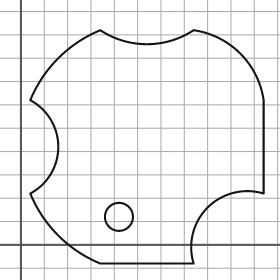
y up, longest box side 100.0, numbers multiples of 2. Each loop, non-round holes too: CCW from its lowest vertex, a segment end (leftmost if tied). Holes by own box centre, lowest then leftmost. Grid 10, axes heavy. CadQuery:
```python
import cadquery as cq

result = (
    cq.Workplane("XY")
    .moveTo(34.0, -8.0)
    .lineTo(74.0, -8.0)
    .threePointArc((80.0, 16.0), (104.0, 22.0))
    .lineTo(104.0, 62.0)
    .threePointArc((94.0, 82.0), (74.0, 92.0))
    .threePointArc((54.0, 86.0), (34.0, 92.0))
    .threePointArc((16.0, 80.0), (4.0, 62.0))
    .threePointArc((16.0, 42.0), (4.0, 22.0))
    .threePointArc((16.0, 4.0), (34.0, -8.0))
    .close()
    .moveTo(42.0, 12.0)
    .circle(6.0)
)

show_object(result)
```